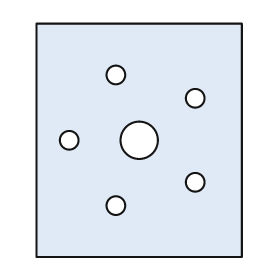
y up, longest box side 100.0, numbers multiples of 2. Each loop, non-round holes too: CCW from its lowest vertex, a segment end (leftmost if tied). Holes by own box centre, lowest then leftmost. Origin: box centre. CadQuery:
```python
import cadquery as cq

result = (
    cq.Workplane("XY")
    .moveTo(-44.0, -50.0)
    .lineTo(44.0, -50.0)
    .lineTo(44.0, 50.0)
    .lineTo(-44.0, 50.0)
    .close()
    .moveTo(-10.0, -28.0)
    .circle(4.0)
    .moveTo(24.0, -18.0)
    .circle(4.0)
    .moveTo(-30.0, 0.0)
    .circle(4.0)
    .moveTo(0.0, 0.0)
    .circle(8.0)
    .moveTo(24.0, 18.0)
    .circle(4.0)
    .moveTo(-10.0, 28.0)
    .circle(4.0)
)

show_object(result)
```